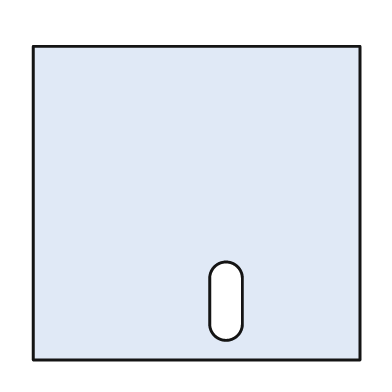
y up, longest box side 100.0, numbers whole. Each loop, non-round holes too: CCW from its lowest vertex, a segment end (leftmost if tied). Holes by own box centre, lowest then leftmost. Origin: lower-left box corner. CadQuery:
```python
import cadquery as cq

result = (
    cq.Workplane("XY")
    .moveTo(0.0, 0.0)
    .lineTo(100.0, 0.0)
    .lineTo(100.0, 96.0)
    .lineTo(0.0, 96.0)
    .close()
    .moveTo(54.0, 11.0)
    .threePointArc((59.0, 6.0), (64.0, 11.0))
    .lineTo(64.0, 25.0)
    .threePointArc((59.0, 30.0), (54.0, 25.0))
    .close()
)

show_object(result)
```